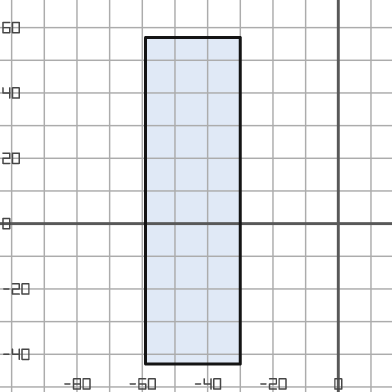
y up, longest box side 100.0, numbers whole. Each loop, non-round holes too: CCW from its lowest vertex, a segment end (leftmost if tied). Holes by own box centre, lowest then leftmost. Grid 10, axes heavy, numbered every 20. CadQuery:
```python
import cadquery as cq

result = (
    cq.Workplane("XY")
    .moveTo(-59.0, -43.0)
    .lineTo(-30.0, -43.0)
    .lineTo(-30.0, 57.0)
    .lineTo(-59.0, 57.0)
    .close()
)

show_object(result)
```